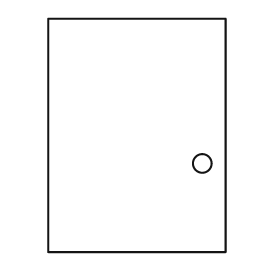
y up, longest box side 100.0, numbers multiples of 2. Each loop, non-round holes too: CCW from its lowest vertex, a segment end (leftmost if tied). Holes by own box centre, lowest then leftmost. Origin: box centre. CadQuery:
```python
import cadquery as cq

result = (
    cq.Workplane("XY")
    .moveTo(-38.0, -50.0)
    .lineTo(38.0, -50.0)
    .lineTo(38.0, 50.0)
    .lineTo(-38.0, 50.0)
    .close()
    .moveTo(28.0, -12.0)
    .circle(4.0)
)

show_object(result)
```